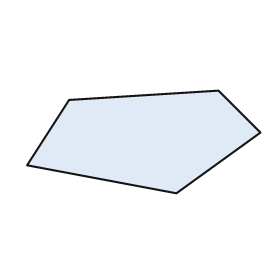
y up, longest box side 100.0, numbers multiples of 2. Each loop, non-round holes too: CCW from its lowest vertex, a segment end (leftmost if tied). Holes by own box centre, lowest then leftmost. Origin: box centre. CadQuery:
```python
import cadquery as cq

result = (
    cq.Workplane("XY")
    .moveTo(14.0, -22.0)
    .lineTo(50.0, 4.0)
    .lineTo(32.0, 22.0)
    .lineTo(-32.0, 18.0)
    .lineTo(-50.0, -10.0)
    .close()
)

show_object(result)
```